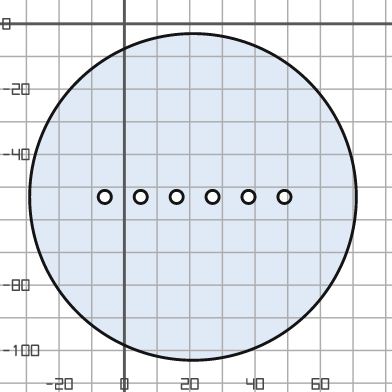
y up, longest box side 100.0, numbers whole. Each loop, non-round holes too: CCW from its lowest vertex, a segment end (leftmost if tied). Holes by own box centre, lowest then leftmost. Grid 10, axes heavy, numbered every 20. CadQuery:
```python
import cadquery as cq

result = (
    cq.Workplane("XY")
    .moveTo(21.0, -53.0)
    .circle(50.0)
    .moveTo(-6.0, -53.0)
    .circle(2.0)
    .moveTo(5.0, -53.0)
    .circle(2.0)
    .moveTo(16.0, -53.0)
    .circle(2.0)
    .moveTo(27.0, -53.0)
    .circle(2.0)
    .moveTo(38.0, -53.0)
    .circle(2.0)
    .moveTo(49.0, -53.0)
    .circle(2.0)
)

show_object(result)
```